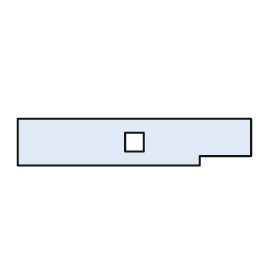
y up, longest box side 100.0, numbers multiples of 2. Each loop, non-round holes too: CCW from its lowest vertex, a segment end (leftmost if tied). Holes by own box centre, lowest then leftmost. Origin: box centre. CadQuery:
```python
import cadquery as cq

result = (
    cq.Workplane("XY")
    .moveTo(-50.0, -10.0)
    .lineTo(28.0, -10.0)
    .lineTo(28.0, -6.0)
    .lineTo(50.0, -6.0)
    .lineTo(50.0, 10.0)
    .lineTo(-50.0, 10.0)
    .close()
    .moveTo(-4.0, -4.0)
    .lineTo(4.0, -4.0)
    .lineTo(4.0, 4.0)
    .lineTo(-4.0, 4.0)
    .close()
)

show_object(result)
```